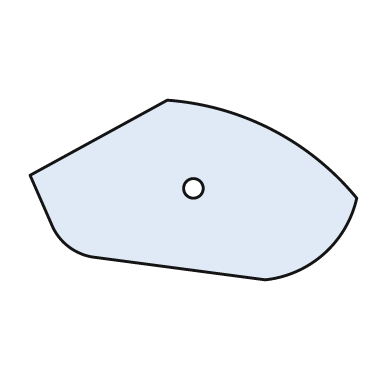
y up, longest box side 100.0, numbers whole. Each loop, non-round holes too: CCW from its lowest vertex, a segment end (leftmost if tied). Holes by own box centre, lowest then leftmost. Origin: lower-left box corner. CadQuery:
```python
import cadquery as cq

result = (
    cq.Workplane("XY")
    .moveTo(72.0, 0.0)
    .threePointArc((90.0, 8.0), (100.0, 25.0))
    .threePointArc((74.0, 46.0), (42.0, 55.0))
    .lineTo(0.0, 32.0)
    .lineTo(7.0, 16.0)
    .threePointArc((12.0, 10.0), (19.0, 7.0))
    .close()
    .moveTo(50.0, 28.0)
    .circle(3.0)
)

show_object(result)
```